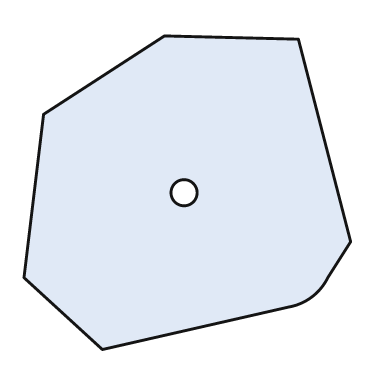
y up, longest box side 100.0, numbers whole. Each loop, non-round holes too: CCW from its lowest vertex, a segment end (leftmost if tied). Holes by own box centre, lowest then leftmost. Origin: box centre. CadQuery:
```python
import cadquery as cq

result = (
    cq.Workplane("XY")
    .moveTo(-26.0, -48.0)
    .lineTo(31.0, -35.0)
    .threePointArc((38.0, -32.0), (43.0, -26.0))
    .lineTo(50.0, -15.0)
    .lineTo(34.0, 47.0)
    .lineTo(-7.0, 48.0)
    .lineTo(-44.0, 24.0)
    .lineTo(-50.0, -26.0)
    .close()
    .moveTo(-1.0, 0.0)
    .circle(4.0)
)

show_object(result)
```